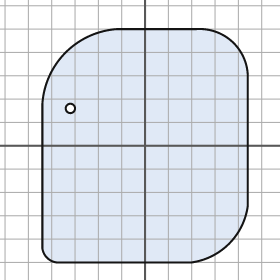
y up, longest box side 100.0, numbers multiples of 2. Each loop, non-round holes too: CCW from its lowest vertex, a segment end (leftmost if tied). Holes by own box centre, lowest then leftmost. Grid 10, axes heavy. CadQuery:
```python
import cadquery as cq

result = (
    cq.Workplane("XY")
    .moveTo(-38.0, -50.0)
    .lineTo(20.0, -50.0)
    .threePointArc((36.0, -42.0), (44.0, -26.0))
    .lineTo(44.0, 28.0)
    .threePointArc((38.0, 44.0), (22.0, 50.0))
    .lineTo(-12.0, 50.0)
    .threePointArc((-34.0, 40.0), (-44.0, 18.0))
    .lineTo(-44.0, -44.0)
    .threePointArc((-42.0, -48.0), (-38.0, -50.0))
    .close()
    .moveTo(-32.0, 16.0)
    .circle(2.0)
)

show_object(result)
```